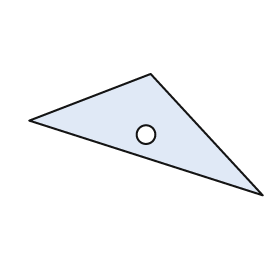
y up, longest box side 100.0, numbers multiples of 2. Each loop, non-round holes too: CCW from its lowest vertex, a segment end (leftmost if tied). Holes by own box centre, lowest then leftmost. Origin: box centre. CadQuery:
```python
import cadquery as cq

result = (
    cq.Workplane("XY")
    .moveTo(50.0, -26.0)
    .lineTo(2.0, 26.0)
    .lineTo(-50.0, 6.0)
    .close()
    .moveTo(0.0, 0.0)
    .circle(4.0)
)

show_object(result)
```